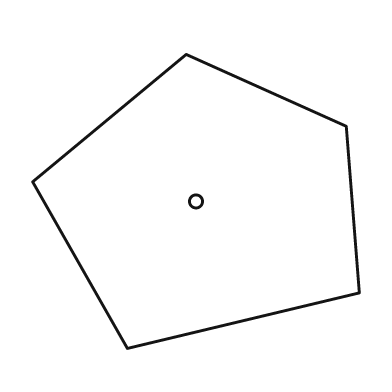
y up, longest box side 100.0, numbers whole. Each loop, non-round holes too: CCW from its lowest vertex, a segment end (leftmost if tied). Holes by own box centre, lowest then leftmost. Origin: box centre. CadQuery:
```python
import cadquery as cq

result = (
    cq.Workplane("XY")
    .moveTo(-21.0, -45.0)
    .lineTo(50.0, -28.0)
    .lineTo(46.0, 23.0)
    .lineTo(-3.0, 45.0)
    .lineTo(-50.0, 6.0)
    .close()
    .moveTo(0.0, 0.0)
    .circle(2.0)
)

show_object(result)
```